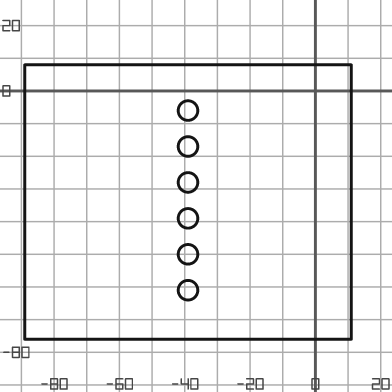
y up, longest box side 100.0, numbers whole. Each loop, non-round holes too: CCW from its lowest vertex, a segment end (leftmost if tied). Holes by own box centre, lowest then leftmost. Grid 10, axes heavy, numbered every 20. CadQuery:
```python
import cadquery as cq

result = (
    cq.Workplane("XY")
    .moveTo(-89.0, -76.0)
    .lineTo(11.0, -76.0)
    .lineTo(11.0, 8.0)
    .lineTo(-89.0, 8.0)
    .close()
    .moveTo(-39.0, -61.0)
    .circle(3.0)
    .moveTo(-39.0, -50.0)
    .circle(3.0)
    .moveTo(-39.0, -39.0)
    .circle(3.0)
    .moveTo(-39.0, -28.0)
    .circle(3.0)
    .moveTo(-39.0, -17.0)
    .circle(3.0)
    .moveTo(-39.0, -6.0)
    .circle(3.0)
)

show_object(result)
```